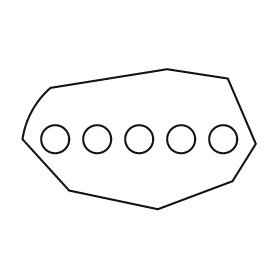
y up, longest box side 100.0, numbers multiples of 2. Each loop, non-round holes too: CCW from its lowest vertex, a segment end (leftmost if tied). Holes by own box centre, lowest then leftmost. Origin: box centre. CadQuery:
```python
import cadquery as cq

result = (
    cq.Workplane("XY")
    .moveTo(8.0, -30.0)
    .lineTo(40.0, -18.0)
    .lineTo(50.0, -2.0)
    .lineTo(38.0, 26.0)
    .lineTo(12.0, 30.0)
    .lineTo(-38.0, 22.0)
    .threePointArc((-46.0, 12.0), (-50.0, 0.0))
    .lineTo(-30.0, -22.0)
    .close()
    .moveTo(-36.0, 0.0)
    .circle(6.0)
    .moveTo(-18.0, 0.0)
    .circle(6.0)
    .moveTo(0.0, 0.0)
    .circle(6.0)
    .moveTo(18.0, 0.0)
    .circle(6.0)
    .moveTo(36.0, 0.0)
    .circle(6.0)
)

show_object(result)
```